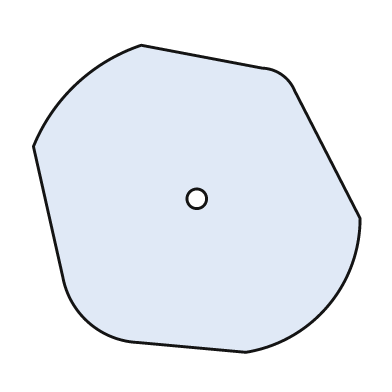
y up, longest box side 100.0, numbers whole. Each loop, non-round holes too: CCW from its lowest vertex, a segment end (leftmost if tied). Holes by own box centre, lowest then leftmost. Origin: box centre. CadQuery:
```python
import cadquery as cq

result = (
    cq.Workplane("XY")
    .moveTo(15.0, -47.0)
    .threePointArc((40.0, -33.0), (50.0, -6.0))
    .lineTo(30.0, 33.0)
    .threePointArc((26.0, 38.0), (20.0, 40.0))
    .lineTo(-17.0, 47.0)
    .threePointArc((-37.0, 35.0), (-50.0, 16.0))
    .lineTo(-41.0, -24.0)
    .threePointArc((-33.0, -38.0), (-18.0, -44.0))
    .close()
    .moveTo(0.0, 0.0)
    .circle(3.0)
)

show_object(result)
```